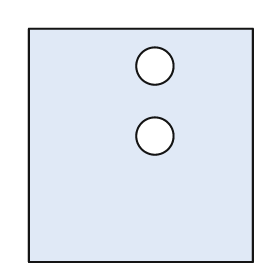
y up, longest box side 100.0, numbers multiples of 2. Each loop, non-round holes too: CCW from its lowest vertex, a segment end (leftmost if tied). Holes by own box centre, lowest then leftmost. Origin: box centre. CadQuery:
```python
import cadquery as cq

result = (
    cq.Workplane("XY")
    .moveTo(-48.0, -50.0)
    .lineTo(48.0, -50.0)
    .lineTo(48.0, 50.0)
    .lineTo(-48.0, 50.0)
    .close()
    .moveTo(6.0, 4.0)
    .circle(8.0)
    .moveTo(6.0, 34.0)
    .circle(8.0)
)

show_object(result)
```